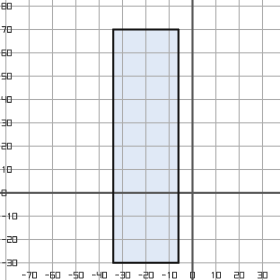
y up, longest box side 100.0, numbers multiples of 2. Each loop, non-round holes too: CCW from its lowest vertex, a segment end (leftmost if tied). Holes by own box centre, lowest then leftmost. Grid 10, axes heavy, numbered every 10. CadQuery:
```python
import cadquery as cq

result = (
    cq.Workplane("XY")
    .moveTo(-34.0, -30.0)
    .lineTo(-6.0, -30.0)
    .lineTo(-6.0, 70.0)
    .lineTo(-34.0, 70.0)
    .close()
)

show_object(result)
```